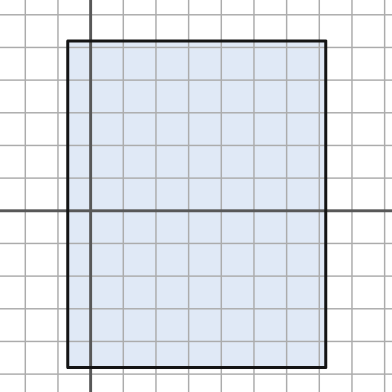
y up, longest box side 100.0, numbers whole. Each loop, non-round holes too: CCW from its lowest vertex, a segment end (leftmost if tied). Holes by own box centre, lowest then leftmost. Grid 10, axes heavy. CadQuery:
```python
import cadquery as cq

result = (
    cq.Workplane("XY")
    .moveTo(-7.0, -48.0)
    .lineTo(72.0, -48.0)
    .lineTo(72.0, 52.0)
    .lineTo(-7.0, 52.0)
    .close()
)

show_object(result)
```